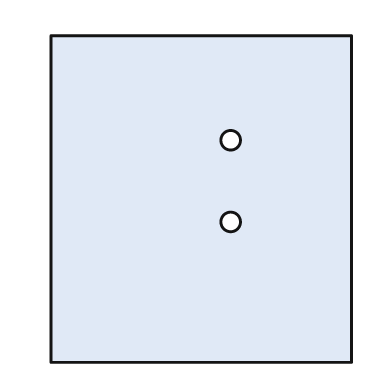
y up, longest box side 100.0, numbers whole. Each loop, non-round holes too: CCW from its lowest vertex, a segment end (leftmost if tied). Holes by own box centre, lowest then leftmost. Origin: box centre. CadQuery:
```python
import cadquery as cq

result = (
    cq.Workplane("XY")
    .moveTo(-46.0, -50.0)
    .lineTo(46.0, -50.0)
    .lineTo(46.0, 50.0)
    .lineTo(-46.0, 50.0)
    .close()
    .moveTo(9.0, -7.0)
    .circle(3.0)
    .moveTo(9.0, 18.0)
    .circle(3.0)
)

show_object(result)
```